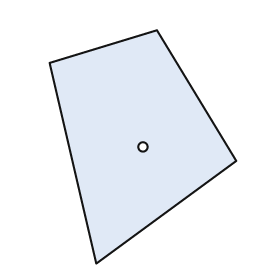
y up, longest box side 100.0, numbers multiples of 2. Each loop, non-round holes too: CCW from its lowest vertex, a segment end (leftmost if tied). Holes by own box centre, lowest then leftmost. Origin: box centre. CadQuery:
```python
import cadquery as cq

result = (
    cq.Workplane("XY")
    .moveTo(-20.0, -50.0)
    .lineTo(40.0, -6.0)
    .lineTo(6.0, 50.0)
    .lineTo(-40.0, 36.0)
    .close()
    .moveTo(0.0, 0.0)
    .circle(2.0)
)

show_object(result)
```